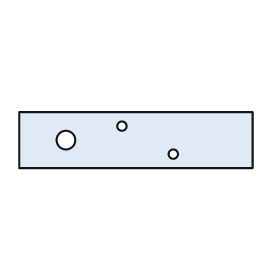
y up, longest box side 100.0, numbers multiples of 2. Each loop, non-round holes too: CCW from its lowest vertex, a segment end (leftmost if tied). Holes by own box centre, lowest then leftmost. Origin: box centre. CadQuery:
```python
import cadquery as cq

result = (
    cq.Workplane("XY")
    .moveTo(-50.0, -12.0)
    .lineTo(50.0, -12.0)
    .lineTo(50.0, 12.0)
    .lineTo(-50.0, 12.0)
    .close()
    .moveTo(16.0, -6.0)
    .circle(2.0)
    .moveTo(-30.0, 0.0)
    .circle(4.0)
    .moveTo(-6.0, 6.0)
    .circle(2.0)
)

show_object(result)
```